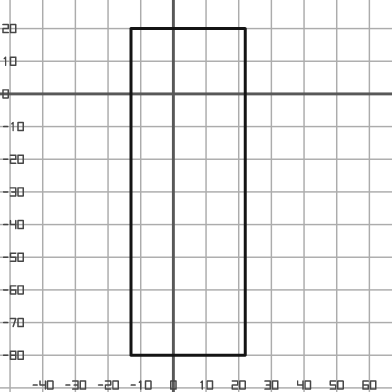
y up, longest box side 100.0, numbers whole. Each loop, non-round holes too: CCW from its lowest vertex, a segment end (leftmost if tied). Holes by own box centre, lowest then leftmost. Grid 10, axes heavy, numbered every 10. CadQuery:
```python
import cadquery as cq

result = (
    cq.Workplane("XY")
    .moveTo(-13.0, -80.0)
    .lineTo(22.0, -80.0)
    .lineTo(22.0, 20.0)
    .lineTo(-13.0, 20.0)
    .close()
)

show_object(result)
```